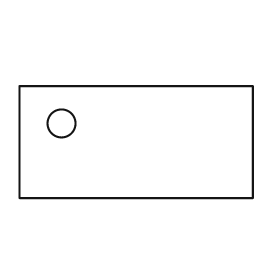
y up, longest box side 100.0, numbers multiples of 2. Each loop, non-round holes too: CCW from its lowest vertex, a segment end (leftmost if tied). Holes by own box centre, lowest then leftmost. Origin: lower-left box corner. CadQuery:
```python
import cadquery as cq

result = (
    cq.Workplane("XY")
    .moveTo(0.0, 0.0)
    .lineTo(100.0, 0.0)
    .lineTo(100.0, 48.0)
    .lineTo(0.0, 48.0)
    .close()
    .moveTo(18.0, 32.0)
    .circle(6.0)
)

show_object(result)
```